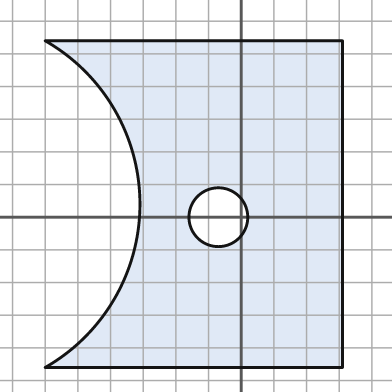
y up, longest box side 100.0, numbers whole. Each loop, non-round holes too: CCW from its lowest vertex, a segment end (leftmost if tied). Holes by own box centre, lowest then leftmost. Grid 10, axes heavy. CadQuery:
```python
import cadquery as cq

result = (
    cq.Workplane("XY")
    .moveTo(-60.0, -46.0)
    .lineTo(31.0, -46.0)
    .lineTo(31.0, 54.0)
    .lineTo(-60.0, 54.0)
    .threePointArc((-31.0, 4.0), (-60.0, -46.0))
    .close()
    .moveTo(-7.0, 0.0)
    .circle(9.0)
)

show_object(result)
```